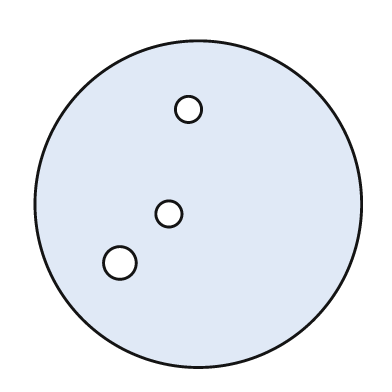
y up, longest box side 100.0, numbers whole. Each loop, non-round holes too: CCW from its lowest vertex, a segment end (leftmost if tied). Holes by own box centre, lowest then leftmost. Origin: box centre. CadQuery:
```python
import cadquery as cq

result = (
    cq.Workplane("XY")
    .moveTo(0.0, 0.0)
    .circle(50.0)
    .moveTo(-24.0, -18.0)
    .circle(5.0)
    .moveTo(-9.0, -3.0)
    .circle(4.0)
    .moveTo(-3.0, 29.0)
    .circle(4.0)
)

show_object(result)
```